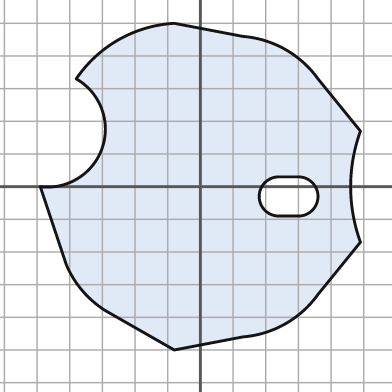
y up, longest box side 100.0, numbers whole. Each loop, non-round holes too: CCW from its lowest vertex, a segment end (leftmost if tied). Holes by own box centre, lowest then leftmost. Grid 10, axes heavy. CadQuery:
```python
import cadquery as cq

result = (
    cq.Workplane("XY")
    .moveTo(-8.0, -50.0)
    .lineTo(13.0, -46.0)
    .threePointArc((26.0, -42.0), (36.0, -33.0))
    .lineTo(49.0, -17.0)
    .threePointArc((46.0, 0.0), (49.0, 17.0))
    .lineTo(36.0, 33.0)
    .threePointArc((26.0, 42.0), (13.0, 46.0))
    .lineTo(-8.0, 50.0)
    .threePointArc((-25.0, 45.0), (-38.0, 33.0))
    .threePointArc((-30.0, 12.0), (-49.0, 0.0))
    .lineTo(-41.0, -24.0)
    .threePointArc((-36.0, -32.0), (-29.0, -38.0))
    .close()
    .moveTo(24.0, -9.0)
    .lineTo(30.0, -9.0)
    .threePointArc((36.0, -3.0), (30.0, 3.0))
    .lineTo(24.0, 3.0)
    .threePointArc((18.0, -3.0), (24.0, -9.0))
    .close()
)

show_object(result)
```